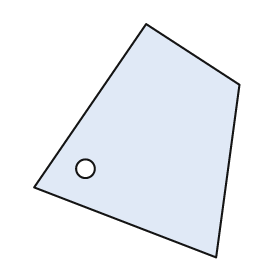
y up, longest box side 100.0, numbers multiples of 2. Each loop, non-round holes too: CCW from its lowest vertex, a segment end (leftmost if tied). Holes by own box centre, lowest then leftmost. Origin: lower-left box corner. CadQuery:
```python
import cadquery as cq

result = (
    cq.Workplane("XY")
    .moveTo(78.0, 0.0)
    .lineTo(88.0, 74.0)
    .lineTo(48.0, 100.0)
    .lineTo(0.0, 30.0)
    .close()
    .moveTo(22.0, 38.0)
    .circle(4.0)
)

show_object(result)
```